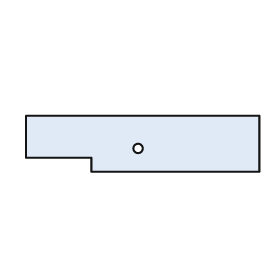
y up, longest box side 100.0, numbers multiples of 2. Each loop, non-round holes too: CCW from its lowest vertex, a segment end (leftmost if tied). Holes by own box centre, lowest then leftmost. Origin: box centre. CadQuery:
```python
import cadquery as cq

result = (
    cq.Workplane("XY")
    .moveTo(-22.0, -12.0)
    .lineTo(50.0, -12.0)
    .lineTo(50.0, 12.0)
    .lineTo(-50.0, 12.0)
    .lineTo(-50.0, -6.0)
    .lineTo(-22.0, -6.0)
    .close()
    .moveTo(-2.0, -2.0)
    .circle(2.0)
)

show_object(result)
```